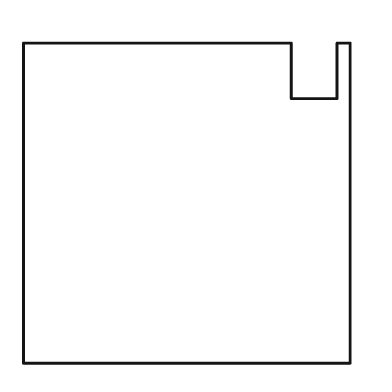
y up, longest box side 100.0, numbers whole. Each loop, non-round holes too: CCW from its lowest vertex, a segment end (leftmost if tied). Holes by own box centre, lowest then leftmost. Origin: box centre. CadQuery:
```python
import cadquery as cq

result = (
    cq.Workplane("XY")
    .moveTo(-50.0, -49.0)
    .lineTo(50.0, -49.0)
    .lineTo(50.0, 49.0)
    .lineTo(46.0, 49.0)
    .lineTo(46.0, 32.0)
    .lineTo(32.0, 32.0)
    .lineTo(32.0, 49.0)
    .lineTo(-50.0, 49.0)
    .close()
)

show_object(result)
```